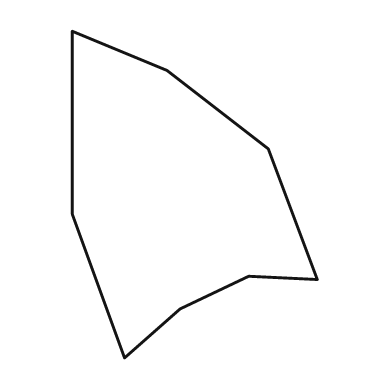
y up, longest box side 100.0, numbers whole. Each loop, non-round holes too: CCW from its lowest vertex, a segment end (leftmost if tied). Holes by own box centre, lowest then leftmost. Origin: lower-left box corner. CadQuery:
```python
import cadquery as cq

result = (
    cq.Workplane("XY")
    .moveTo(16.0, 0.0)
    .lineTo(33.0, 15.0)
    .lineTo(54.0, 25.0)
    .lineTo(75.0, 24.0)
    .lineTo(60.0, 64.0)
    .lineTo(29.0, 88.0)
    .lineTo(0.0, 100.0)
    .lineTo(0.0, 44.0)
    .close()
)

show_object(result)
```